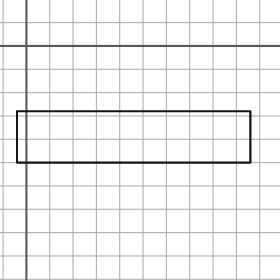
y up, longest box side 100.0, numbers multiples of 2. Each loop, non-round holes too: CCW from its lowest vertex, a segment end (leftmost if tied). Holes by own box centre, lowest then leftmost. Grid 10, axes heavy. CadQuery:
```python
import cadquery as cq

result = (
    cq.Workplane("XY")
    .moveTo(-4.0, -50.0)
    .lineTo(96.0, -50.0)
    .lineTo(96.0, -28.0)
    .lineTo(-4.0, -28.0)
    .close()
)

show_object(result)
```